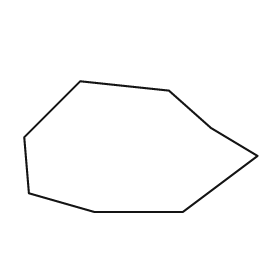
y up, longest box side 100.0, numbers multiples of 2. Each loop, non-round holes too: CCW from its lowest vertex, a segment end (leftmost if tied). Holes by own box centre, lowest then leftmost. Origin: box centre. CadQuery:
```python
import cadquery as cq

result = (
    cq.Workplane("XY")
    .moveTo(-20.0, -28.0)
    .lineTo(18.0, -28.0)
    .lineTo(50.0, -4.0)
    .lineTo(30.0, 8.0)
    .lineTo(12.0, 24.0)
    .lineTo(-26.0, 28.0)
    .lineTo(-50.0, 4.0)
    .lineTo(-48.0, -20.0)
    .close()
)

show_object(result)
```